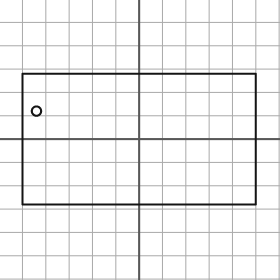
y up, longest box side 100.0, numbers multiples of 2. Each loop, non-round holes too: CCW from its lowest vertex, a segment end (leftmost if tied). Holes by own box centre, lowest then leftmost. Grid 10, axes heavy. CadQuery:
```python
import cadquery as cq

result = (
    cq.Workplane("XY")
    .moveTo(-50.0, -28.0)
    .lineTo(50.0, -28.0)
    .lineTo(50.0, 28.0)
    .lineTo(-50.0, 28.0)
    .close()
    .moveTo(-44.0, 12.0)
    .circle(2.0)
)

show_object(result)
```